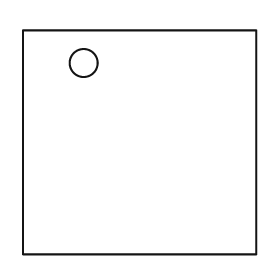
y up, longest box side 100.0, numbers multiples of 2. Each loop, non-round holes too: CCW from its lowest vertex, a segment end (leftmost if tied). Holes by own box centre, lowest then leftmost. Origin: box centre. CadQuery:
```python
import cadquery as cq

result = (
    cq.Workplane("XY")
    .moveTo(-50.0, -48.0)
    .lineTo(50.0, -48.0)
    .lineTo(50.0, 48.0)
    .lineTo(-50.0, 48.0)
    .close()
    .moveTo(-24.0, 34.0)
    .circle(6.0)
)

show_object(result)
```